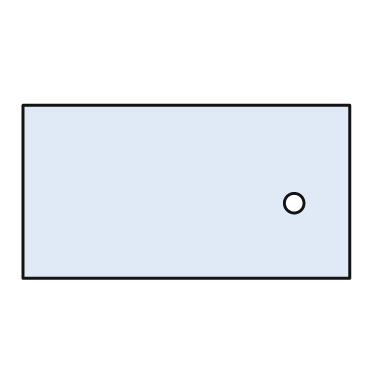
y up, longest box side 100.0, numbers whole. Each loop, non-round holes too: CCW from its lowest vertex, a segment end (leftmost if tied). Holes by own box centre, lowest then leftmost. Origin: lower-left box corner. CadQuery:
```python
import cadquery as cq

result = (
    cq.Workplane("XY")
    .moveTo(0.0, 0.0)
    .lineTo(100.0, 0.0)
    .lineTo(100.0, 53.0)
    .lineTo(0.0, 53.0)
    .close()
    .moveTo(83.0, 23.0)
    .circle(3.0)
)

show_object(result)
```